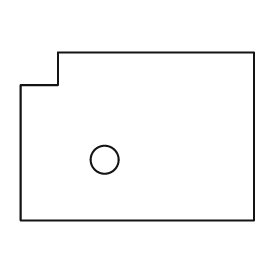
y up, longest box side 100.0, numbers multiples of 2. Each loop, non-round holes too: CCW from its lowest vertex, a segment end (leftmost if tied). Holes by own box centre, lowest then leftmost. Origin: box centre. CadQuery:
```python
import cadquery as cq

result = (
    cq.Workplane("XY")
    .moveTo(-50.0, -36.0)
    .lineTo(50.0, -36.0)
    .lineTo(50.0, 36.0)
    .lineTo(-34.0, 36.0)
    .lineTo(-34.0, 22.0)
    .lineTo(-50.0, 22.0)
    .close()
    .moveTo(-14.0, -10.0)
    .circle(6.0)
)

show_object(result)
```